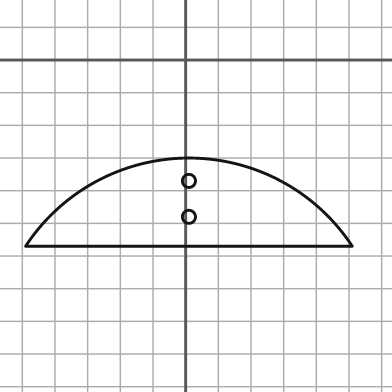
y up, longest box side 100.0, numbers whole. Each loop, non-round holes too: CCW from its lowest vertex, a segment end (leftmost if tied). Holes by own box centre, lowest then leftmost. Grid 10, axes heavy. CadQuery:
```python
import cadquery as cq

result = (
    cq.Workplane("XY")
    .moveTo(-49.0, -57.0)
    .lineTo(51.0, -57.0)
    .threePointArc((1.0, -30.0), (-49.0, -57.0))
    .close()
    .moveTo(1.0, -48.0)
    .circle(2.0)
    .moveTo(1.0, -37.0)
    .circle(2.0)
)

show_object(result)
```